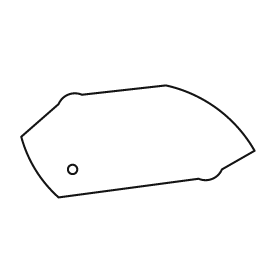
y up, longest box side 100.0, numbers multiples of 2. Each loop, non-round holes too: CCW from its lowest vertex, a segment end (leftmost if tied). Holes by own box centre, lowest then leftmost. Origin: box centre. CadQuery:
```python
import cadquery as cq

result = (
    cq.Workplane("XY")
    .moveTo(-34.0, -24.0)
    .lineTo(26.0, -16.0)
    .threePointArc((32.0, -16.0), (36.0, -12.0))
    .lineTo(50.0, -4.0)
    .threePointArc((34.0, 14.0), (12.0, 24.0))
    .lineTo(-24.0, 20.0)
    .threePointArc((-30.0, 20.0), (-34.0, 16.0))
    .lineTo(-50.0, 2.0)
    .threePointArc((-44.0, -12.0), (-34.0, -24.0))
    .close()
    .moveTo(-28.0, -12.0)
    .circle(2.0)
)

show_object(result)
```